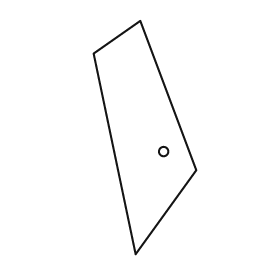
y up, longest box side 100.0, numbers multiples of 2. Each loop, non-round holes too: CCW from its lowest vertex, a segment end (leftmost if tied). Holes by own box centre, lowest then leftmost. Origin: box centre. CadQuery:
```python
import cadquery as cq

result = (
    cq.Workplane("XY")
    .moveTo(-4.0, -50.0)
    .lineTo(22.0, -14.0)
    .lineTo(-2.0, 50.0)
    .lineTo(-22.0, 36.0)
    .close()
    .moveTo(8.0, -6.0)
    .circle(2.0)
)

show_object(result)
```